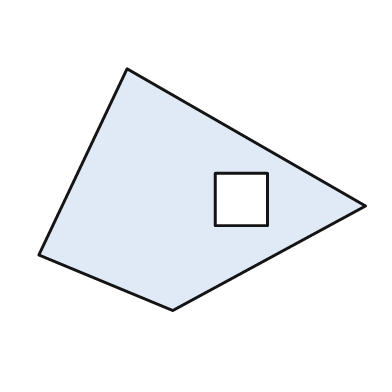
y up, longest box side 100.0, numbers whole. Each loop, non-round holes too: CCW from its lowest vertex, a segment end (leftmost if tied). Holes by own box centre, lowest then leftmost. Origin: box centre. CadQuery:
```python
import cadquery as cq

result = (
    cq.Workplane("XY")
    .moveTo(-9.0, -37.0)
    .lineTo(50.0, -5.0)
    .lineTo(-23.0, 37.0)
    .lineTo(-50.0, -20.0)
    .close()
    .moveTo(4.0, -11.0)
    .lineTo(20.0, -11.0)
    .lineTo(20.0, 5.0)
    .lineTo(4.0, 5.0)
    .close()
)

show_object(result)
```